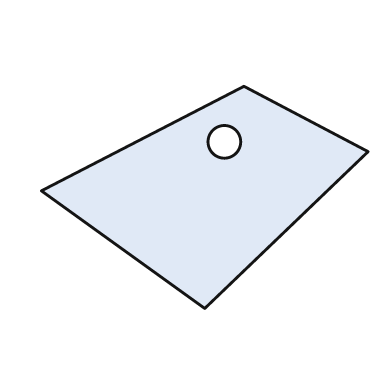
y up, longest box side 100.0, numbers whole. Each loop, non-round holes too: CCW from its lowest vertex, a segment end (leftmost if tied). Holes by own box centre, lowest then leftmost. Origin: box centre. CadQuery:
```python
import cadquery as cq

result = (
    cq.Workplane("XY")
    .moveTo(0.0, -34.0)
    .lineTo(50.0, 14.0)
    .lineTo(12.0, 34.0)
    .lineTo(-50.0, 2.0)
    .close()
    .moveTo(6.0, 17.0)
    .circle(5.0)
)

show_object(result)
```